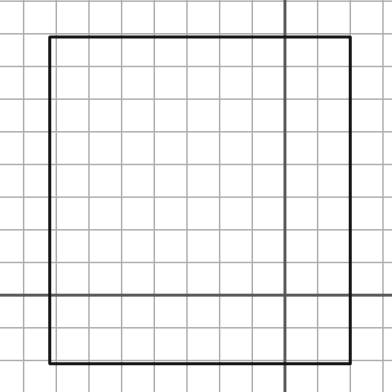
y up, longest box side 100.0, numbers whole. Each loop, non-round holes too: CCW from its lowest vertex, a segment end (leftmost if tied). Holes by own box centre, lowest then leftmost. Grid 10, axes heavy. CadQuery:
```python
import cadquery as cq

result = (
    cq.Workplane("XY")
    .moveTo(-72.0, -21.0)
    .lineTo(20.0, -21.0)
    .lineTo(20.0, 79.0)
    .lineTo(-72.0, 79.0)
    .close()
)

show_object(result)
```